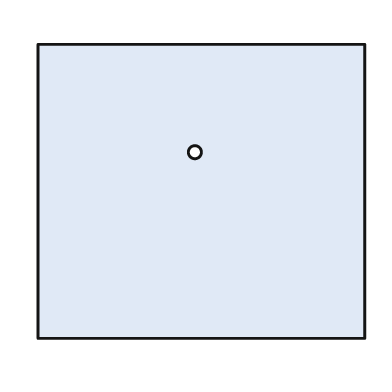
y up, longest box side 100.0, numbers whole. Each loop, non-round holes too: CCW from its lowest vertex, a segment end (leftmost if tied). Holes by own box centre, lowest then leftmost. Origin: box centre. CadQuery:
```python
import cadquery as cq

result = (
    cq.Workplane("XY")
    .moveTo(-50.0, -45.0)
    .lineTo(50.0, -45.0)
    .lineTo(50.0, 45.0)
    .lineTo(-50.0, 45.0)
    .close()
    .moveTo(-2.0, 12.0)
    .circle(2.0)
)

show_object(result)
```